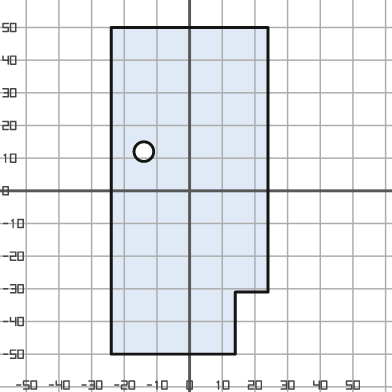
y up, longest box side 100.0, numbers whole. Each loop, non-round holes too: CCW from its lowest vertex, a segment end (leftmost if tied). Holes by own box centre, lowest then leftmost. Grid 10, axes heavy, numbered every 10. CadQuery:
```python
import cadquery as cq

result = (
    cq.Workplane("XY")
    .moveTo(-24.0, -50.0)
    .lineTo(14.0, -50.0)
    .lineTo(14.0, -31.0)
    .lineTo(24.0, -31.0)
    .lineTo(24.0, 50.0)
    .lineTo(-24.0, 50.0)
    .close()
    .moveTo(-14.0, 12.0)
    .circle(3.0)
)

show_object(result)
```